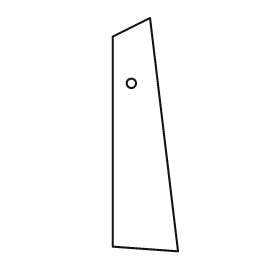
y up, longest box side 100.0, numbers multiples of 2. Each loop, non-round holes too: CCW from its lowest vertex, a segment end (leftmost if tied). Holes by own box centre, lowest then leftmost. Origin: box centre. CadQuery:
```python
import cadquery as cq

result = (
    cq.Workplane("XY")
    .moveTo(14.0, -50.0)
    .lineTo(2.0, 50.0)
    .lineTo(-14.0, 42.0)
    .lineTo(-14.0, -48.0)
    .close()
    .moveTo(-6.0, 22.0)
    .circle(2.0)
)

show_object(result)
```